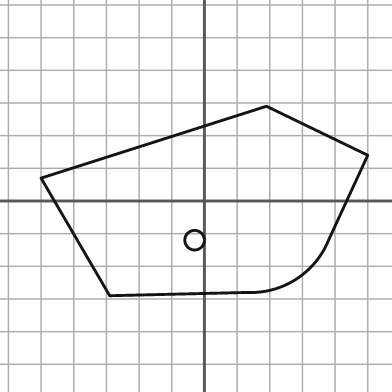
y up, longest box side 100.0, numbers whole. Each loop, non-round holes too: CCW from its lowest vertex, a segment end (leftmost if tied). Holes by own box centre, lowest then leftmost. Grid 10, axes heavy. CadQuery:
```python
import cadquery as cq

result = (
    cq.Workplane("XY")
    .moveTo(-29.0, -29.0)
    .lineTo(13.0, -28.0)
    .threePointArc((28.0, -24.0), (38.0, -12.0))
    .lineTo(50.0, 14.0)
    .lineTo(19.0, 29.0)
    .lineTo(-50.0, 7.0)
    .close()
    .moveTo(-3.0, -12.0)
    .circle(3.0)
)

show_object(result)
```